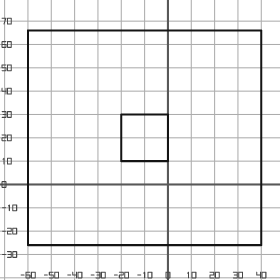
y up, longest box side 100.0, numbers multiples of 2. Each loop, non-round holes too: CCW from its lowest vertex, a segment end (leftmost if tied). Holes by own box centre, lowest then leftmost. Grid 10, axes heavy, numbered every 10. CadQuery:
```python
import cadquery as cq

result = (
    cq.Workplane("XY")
    .moveTo(-60.0, -26.0)
    .lineTo(40.0, -26.0)
    .lineTo(40.0, 66.0)
    .lineTo(-60.0, 66.0)
    .close()
    .moveTo(-20.0, 10.0)
    .lineTo(0.0, 10.0)
    .lineTo(0.0, 30.0)
    .lineTo(-20.0, 30.0)
    .close()
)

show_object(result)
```